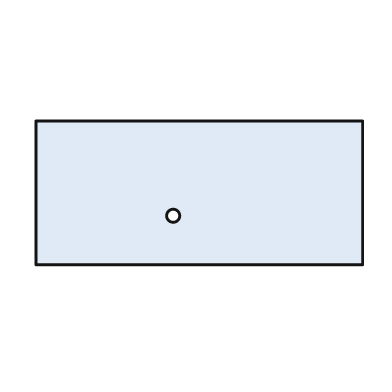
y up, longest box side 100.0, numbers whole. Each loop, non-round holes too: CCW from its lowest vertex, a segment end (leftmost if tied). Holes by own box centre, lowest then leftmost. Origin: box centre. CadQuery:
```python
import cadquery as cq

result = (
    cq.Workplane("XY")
    .moveTo(-50.0, -22.0)
    .lineTo(50.0, -22.0)
    .lineTo(50.0, 22.0)
    .lineTo(-50.0, 22.0)
    .close()
    .moveTo(-8.0, -7.0)
    .circle(2.0)
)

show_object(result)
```